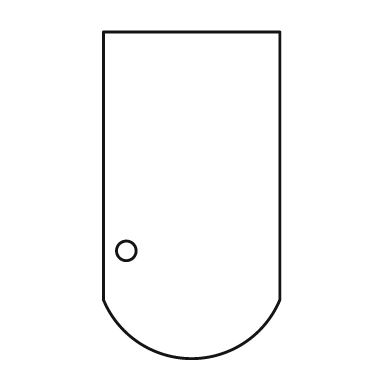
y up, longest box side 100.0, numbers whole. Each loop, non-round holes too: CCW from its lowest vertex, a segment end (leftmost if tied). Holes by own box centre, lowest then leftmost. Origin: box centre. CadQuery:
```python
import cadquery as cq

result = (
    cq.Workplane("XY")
    .moveTo(-27.0, -32.0)
    .threePointArc((0.0, -50.0), (27.0, -32.0))
    .lineTo(27.0, 50.0)
    .lineTo(-27.0, 50.0)
    .close()
    .moveTo(-20.0, -17.0)
    .circle(3.0)
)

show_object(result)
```